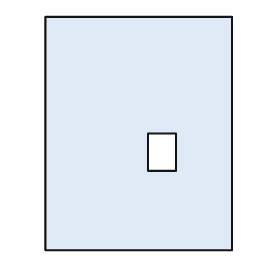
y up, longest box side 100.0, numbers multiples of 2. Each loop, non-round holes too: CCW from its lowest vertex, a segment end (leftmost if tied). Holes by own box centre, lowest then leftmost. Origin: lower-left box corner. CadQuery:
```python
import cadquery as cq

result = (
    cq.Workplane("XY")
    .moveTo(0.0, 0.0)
    .lineTo(80.0, 0.0)
    .lineTo(80.0, 100.0)
    .lineTo(0.0, 100.0)
    .close()
    .moveTo(44.0, 34.0)
    .lineTo(56.0, 34.0)
    .lineTo(56.0, 50.0)
    .lineTo(44.0, 50.0)
    .close()
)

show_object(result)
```